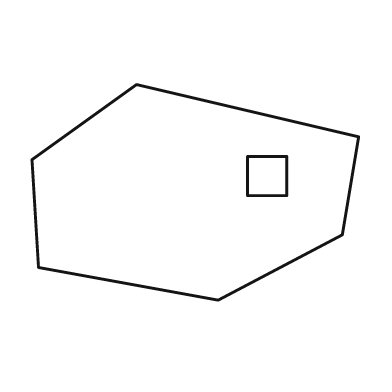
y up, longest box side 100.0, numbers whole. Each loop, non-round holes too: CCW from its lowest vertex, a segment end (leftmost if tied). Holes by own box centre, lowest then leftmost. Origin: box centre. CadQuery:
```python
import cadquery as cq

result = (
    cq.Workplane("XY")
    .moveTo(7.0, -33.0)
    .lineTo(45.0, -13.0)
    .lineTo(50.0, 17.0)
    .lineTo(-18.0, 33.0)
    .lineTo(-50.0, 10.0)
    .lineTo(-48.0, -23.0)
    .close()
    .moveTo(16.0, -1.0)
    .lineTo(28.0, -1.0)
    .lineTo(28.0, 11.0)
    .lineTo(16.0, 11.0)
    .close()
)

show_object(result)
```